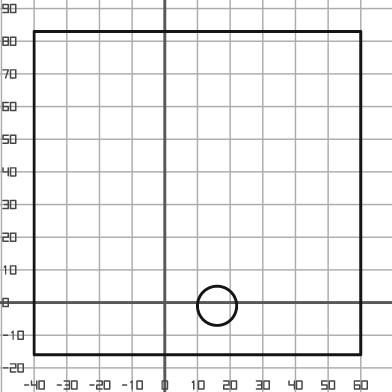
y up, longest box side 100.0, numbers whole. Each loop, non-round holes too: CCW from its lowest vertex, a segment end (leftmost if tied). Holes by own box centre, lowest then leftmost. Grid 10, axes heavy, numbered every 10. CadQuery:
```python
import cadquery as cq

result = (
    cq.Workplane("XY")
    .moveTo(-40.0, -16.0)
    .lineTo(60.0, -16.0)
    .lineTo(60.0, 83.0)
    .lineTo(-40.0, 83.0)
    .close()
    .moveTo(16.0, -1.0)
    .circle(6.0)
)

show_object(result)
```